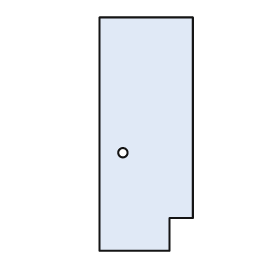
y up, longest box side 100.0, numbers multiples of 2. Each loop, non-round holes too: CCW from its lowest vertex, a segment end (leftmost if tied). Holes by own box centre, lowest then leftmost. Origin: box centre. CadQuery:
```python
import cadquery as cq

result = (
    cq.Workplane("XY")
    .moveTo(-20.0, -50.0)
    .lineTo(10.0, -50.0)
    .lineTo(10.0, -36.0)
    .lineTo(20.0, -36.0)
    .lineTo(20.0, 50.0)
    .lineTo(-20.0, 50.0)
    .close()
    .moveTo(-10.0, -8.0)
    .circle(2.0)
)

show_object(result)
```